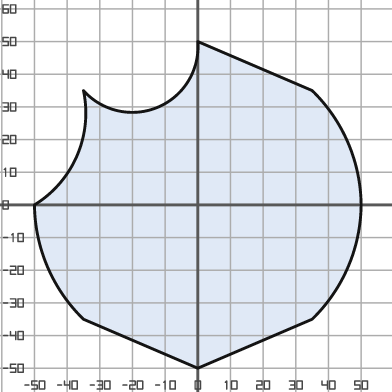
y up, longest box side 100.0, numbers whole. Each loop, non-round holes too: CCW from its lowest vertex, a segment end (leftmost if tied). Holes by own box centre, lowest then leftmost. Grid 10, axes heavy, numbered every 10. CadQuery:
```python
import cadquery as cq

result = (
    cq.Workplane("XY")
    .moveTo(0.0, -50.0)
    .lineTo(35.0, -35.0)
    .threePointArc((46.0, -19.0), (50.0, 0.0))
    .threePointArc((46.0, 19.0), (35.0, 35.0))
    .lineTo(0.0, 50.0)
    .threePointArc((-12.0, 30.0), (-35.0, 35.0))
    .threePointArc((-37.0, 15.0), (-50.0, 0.0))
    .threePointArc((-46.0, -19.0), (-35.0, -35.0))
    .close()
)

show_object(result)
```